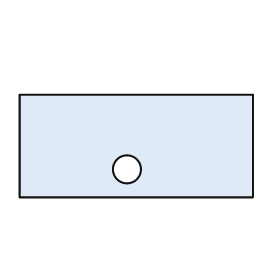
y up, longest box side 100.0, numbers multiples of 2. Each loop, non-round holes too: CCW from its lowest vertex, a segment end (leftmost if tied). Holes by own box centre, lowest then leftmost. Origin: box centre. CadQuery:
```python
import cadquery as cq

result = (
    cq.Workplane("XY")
    .moveTo(-50.0, -22.0)
    .lineTo(50.0, -22.0)
    .lineTo(50.0, 22.0)
    .lineTo(-50.0, 22.0)
    .close()
    .moveTo(-4.0, -10.0)
    .circle(6.0)
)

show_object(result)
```